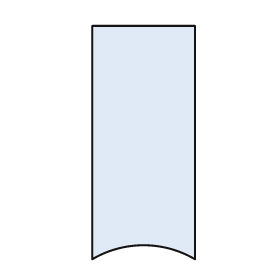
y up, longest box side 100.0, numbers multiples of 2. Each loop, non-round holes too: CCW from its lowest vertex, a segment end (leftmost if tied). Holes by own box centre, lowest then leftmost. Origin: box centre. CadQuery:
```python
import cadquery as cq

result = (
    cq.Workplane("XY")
    .moveTo(-22.0, -50.0)
    .threePointArc((0.0, -44.0), (22.0, -50.0))
    .lineTo(22.0, 50.0)
    .lineTo(-22.0, 50.0)
    .close()
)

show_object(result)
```